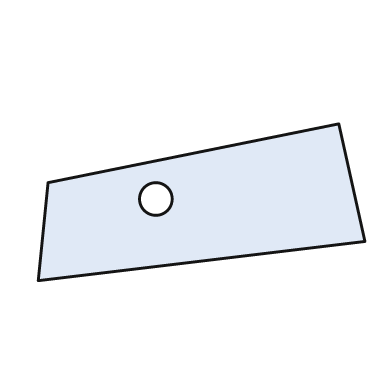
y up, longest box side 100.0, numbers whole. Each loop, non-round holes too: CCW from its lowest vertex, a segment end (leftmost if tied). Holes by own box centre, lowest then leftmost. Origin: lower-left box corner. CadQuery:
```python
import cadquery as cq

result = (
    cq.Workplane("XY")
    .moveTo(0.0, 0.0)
    .lineTo(100.0, 12.0)
    .lineTo(92.0, 48.0)
    .lineTo(3.0, 30.0)
    .close()
    .moveTo(36.0, 25.0)
    .circle(5.0)
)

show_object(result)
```